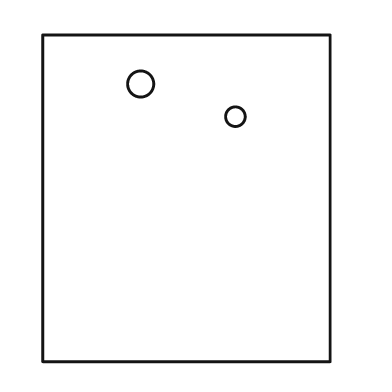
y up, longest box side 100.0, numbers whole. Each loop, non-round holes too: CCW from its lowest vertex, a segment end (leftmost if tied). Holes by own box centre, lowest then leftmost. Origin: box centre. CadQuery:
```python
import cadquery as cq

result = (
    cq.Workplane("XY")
    .moveTo(-44.0, -50.0)
    .lineTo(44.0, -50.0)
    .lineTo(44.0, 50.0)
    .lineTo(-44.0, 50.0)
    .close()
    .moveTo(15.0, 25.0)
    .circle(3.0)
    .moveTo(-14.0, 35.0)
    .circle(4.0)
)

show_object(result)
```